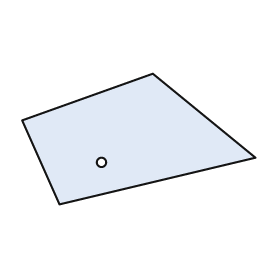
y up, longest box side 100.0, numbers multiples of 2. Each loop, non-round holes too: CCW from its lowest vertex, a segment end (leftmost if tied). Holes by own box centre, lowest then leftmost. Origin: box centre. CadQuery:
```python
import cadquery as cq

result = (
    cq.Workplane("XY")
    .moveTo(-34.0, -28.0)
    .lineTo(50.0, -8.0)
    .lineTo(6.0, 28.0)
    .lineTo(-50.0, 8.0)
    .close()
    .moveTo(-16.0, -10.0)
    .circle(2.0)
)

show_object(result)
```